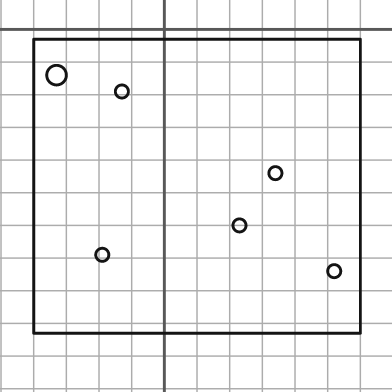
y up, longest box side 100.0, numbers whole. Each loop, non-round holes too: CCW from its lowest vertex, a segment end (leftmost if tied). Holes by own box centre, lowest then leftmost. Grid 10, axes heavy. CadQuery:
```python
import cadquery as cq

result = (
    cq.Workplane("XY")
    .moveTo(-40.0, -93.0)
    .lineTo(60.0, -93.0)
    .lineTo(60.0, -3.0)
    .lineTo(-40.0, -3.0)
    .close()
    .moveTo(52.0, -74.0)
    .circle(2.0)
    .moveTo(-19.0, -69.0)
    .circle(2.0)
    .moveTo(23.0, -60.0)
    .circle(2.0)
    .moveTo(34.0, -44.0)
    .circle(2.0)
    .moveTo(-13.0, -19.0)
    .circle(2.0)
    .moveTo(-33.0, -14.0)
    .circle(3.0)
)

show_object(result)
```